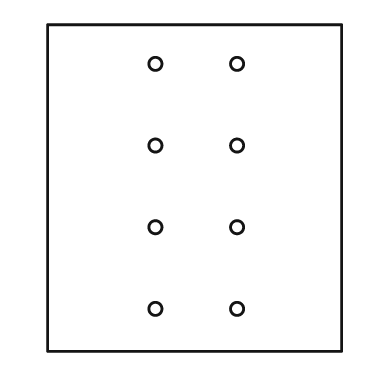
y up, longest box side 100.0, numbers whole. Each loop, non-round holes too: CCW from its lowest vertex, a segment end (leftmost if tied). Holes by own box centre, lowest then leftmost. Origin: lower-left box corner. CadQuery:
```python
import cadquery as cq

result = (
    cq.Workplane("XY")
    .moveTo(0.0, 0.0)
    .lineTo(90.0, 0.0)
    .lineTo(90.0, 100.0)
    .lineTo(0.0, 100.0)
    .close()
    .moveTo(33.0, 13.0)
    .circle(2.0)
    .moveTo(58.0, 13.0)
    .circle(2.0)
    .moveTo(33.0, 38.0)
    .circle(2.0)
    .moveTo(58.0, 38.0)
    .circle(2.0)
    .moveTo(33.0, 63.0)
    .circle(2.0)
    .moveTo(58.0, 63.0)
    .circle(2.0)
    .moveTo(33.0, 88.0)
    .circle(2.0)
    .moveTo(58.0, 88.0)
    .circle(2.0)
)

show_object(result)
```